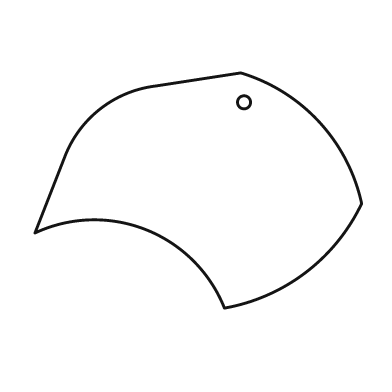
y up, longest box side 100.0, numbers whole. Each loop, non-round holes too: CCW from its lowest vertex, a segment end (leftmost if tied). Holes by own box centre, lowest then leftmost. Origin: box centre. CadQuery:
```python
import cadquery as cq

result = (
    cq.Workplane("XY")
    .moveTo(8.0, -36.0)
    .threePointArc((33.0, -25.0), (50.0, -4.0))
    .threePointArc((37.0, 21.0), (13.0, 36.0))
    .lineTo(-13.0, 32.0)
    .threePointArc((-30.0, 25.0), (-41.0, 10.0))
    .lineTo(-50.0, -13.0)
    .threePointArc((-16.0, -12.0), (8.0, -36.0))
    .close()
    .moveTo(14.0, 27.0)
    .circle(2.0)
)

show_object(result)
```